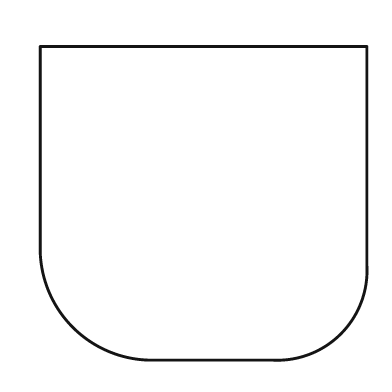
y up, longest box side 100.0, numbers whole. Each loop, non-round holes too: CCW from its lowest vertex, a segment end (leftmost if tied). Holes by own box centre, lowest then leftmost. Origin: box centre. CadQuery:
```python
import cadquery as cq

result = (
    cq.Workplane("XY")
    .moveTo(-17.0, -48.0)
    .lineTo(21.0, -48.0)
    .threePointArc((42.0, -40.0), (50.0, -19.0))
    .lineTo(50.0, 48.0)
    .lineTo(-50.0, 48.0)
    .lineTo(-50.0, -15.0)
    .threePointArc((-40.0, -38.0), (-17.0, -48.0))
    .close()
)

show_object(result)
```